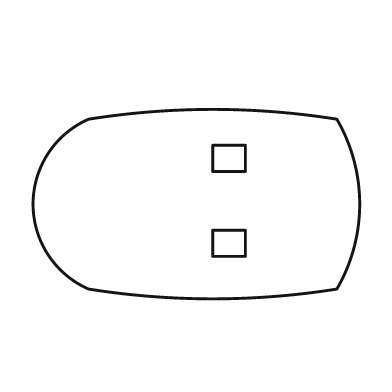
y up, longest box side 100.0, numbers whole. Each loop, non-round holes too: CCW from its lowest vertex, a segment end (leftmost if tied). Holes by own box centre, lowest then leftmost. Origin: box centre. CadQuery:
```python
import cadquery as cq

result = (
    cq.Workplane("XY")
    .moveTo(-33.0, -26.0)
    .threePointArc((5.0, -29.0), (43.0, -26.0))
    .threePointArc((50.0, 0.0), (43.0, 26.0))
    .threePointArc((5.0, 29.0), (-33.0, 26.0))
    .threePointArc((-50.0, 0.0), (-33.0, -26.0))
    .close()
    .moveTo(5.0, -16.0)
    .lineTo(15.0, -16.0)
    .lineTo(15.0, -8.0)
    .lineTo(5.0, -8.0)
    .close()
    .moveTo(5.0, 10.0)
    .lineTo(15.0, 10.0)
    .lineTo(15.0, 18.0)
    .lineTo(5.0, 18.0)
    .close()
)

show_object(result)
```